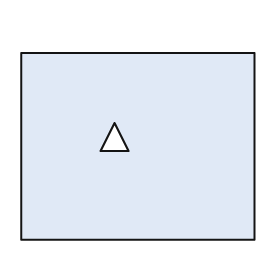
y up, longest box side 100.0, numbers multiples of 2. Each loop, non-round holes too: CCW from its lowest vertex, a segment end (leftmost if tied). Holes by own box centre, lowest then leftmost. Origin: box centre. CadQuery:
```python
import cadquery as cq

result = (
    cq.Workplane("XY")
    .moveTo(-50.0, -40.0)
    .lineTo(50.0, -40.0)
    .lineTo(50.0, 40.0)
    .lineTo(-50.0, 40.0)
    .close()
    .moveTo(-16.0, -2.0)
    .lineTo(-4.0, -2.0)
    .lineTo(-10.0, 10.0)
    .close()
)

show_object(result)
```